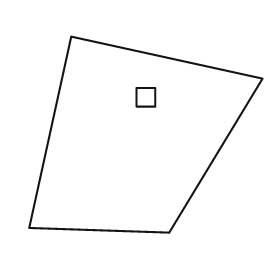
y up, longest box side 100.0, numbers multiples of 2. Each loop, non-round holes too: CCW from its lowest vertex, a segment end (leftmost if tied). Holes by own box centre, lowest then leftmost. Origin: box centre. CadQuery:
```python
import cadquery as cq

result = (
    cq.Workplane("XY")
    .moveTo(10.0, -42.0)
    .lineTo(50.0, 24.0)
    .lineTo(-32.0, 42.0)
    .lineTo(-50.0, -40.0)
    .close()
    .moveTo(-4.0, 12.0)
    .lineTo(4.0, 12.0)
    .lineTo(4.0, 20.0)
    .lineTo(-4.0, 20.0)
    .close()
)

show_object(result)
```